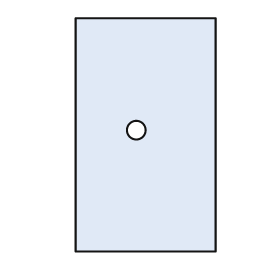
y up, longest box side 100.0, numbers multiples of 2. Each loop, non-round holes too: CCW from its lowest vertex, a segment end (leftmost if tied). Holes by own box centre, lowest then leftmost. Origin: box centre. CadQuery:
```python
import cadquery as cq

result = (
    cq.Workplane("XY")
    .moveTo(-30.0, -50.0)
    .lineTo(30.0, -50.0)
    .lineTo(30.0, 50.0)
    .lineTo(-30.0, 50.0)
    .close()
    .moveTo(-4.0, 2.0)
    .circle(4.0)
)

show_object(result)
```